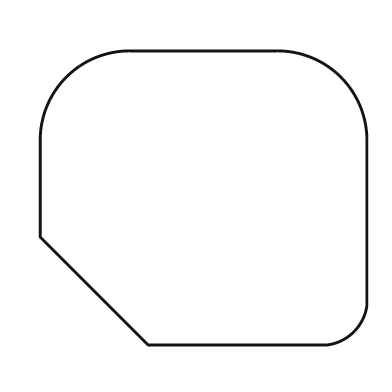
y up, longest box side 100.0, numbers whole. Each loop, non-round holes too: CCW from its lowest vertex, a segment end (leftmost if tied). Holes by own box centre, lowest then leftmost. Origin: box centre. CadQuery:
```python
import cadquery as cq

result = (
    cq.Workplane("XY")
    .moveTo(-17.0, -45.0)
    .lineTo(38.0, -45.0)
    .threePointArc((46.0, -41.0), (50.0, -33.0))
    .lineTo(50.0, 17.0)
    .threePointArc((42.0, 37.0), (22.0, 45.0))
    .lineTo(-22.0, 45.0)
    .threePointArc((-42.0, 37.0), (-50.0, 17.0))
    .lineTo(-50.0, -12.0)
    .close()
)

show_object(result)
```